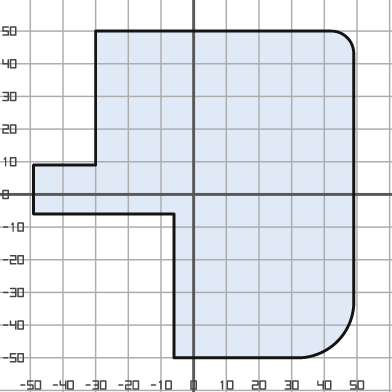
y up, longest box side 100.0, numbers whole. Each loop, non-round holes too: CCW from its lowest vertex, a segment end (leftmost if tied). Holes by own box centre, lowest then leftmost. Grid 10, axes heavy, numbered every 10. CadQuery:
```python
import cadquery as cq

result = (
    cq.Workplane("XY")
    .moveTo(-6.0, -50.0)
    .lineTo(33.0, -50.0)
    .threePointArc((44.0, -45.0), (49.0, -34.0))
    .lineTo(49.0, 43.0)
    .threePointArc((47.0, 48.0), (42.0, 50.0))
    .lineTo(-30.0, 50.0)
    .lineTo(-30.0, 9.0)
    .lineTo(-49.0, 9.0)
    .lineTo(-49.0, -6.0)
    .lineTo(-6.0, -6.0)
    .close()
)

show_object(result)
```